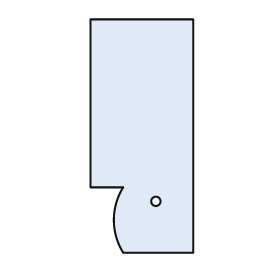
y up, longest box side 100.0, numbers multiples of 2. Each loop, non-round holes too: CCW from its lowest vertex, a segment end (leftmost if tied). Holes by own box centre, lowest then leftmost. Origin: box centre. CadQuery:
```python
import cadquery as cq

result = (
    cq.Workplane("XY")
    .moveTo(-8.0, -50.0)
    .lineTo(22.0, -50.0)
    .lineTo(22.0, 50.0)
    .lineTo(-22.0, 50.0)
    .lineTo(-22.0, -22.0)
    .lineTo(-8.0, -22.0)
    .threePointArc((-12.0, -36.0), (-8.0, -50.0))
    .close()
    .moveTo(6.0, -28.0)
    .circle(2.0)
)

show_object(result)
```